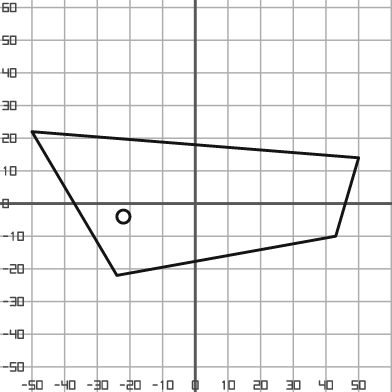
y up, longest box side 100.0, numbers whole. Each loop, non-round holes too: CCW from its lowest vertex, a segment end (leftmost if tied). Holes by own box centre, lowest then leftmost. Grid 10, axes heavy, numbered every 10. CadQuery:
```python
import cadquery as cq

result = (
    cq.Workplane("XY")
    .moveTo(-24.0, -22.0)
    .lineTo(43.0, -10.0)
    .lineTo(50.0, 14.0)
    .lineTo(-50.0, 22.0)
    .close()
    .moveTo(-22.0, -4.0)
    .circle(2.0)
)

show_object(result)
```